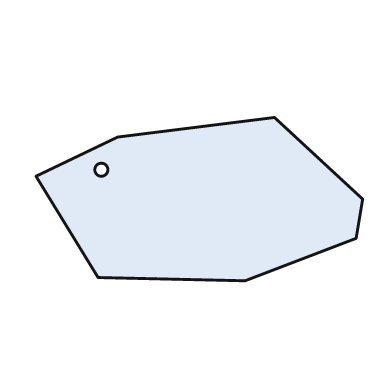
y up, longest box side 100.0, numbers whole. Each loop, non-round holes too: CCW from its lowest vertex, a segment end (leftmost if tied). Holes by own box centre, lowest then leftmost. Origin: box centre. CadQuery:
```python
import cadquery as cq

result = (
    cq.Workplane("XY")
    .moveTo(14.0, -25.0)
    .lineTo(48.0, -12.0)
    .lineTo(50.0, 0.0)
    .lineTo(23.0, 25.0)
    .lineTo(-25.0, 19.0)
    .lineTo(-50.0, 7.0)
    .lineTo(-31.0, -24.0)
    .close()
    .moveTo(-30.0, 9.0)
    .circle(2.0)
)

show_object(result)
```